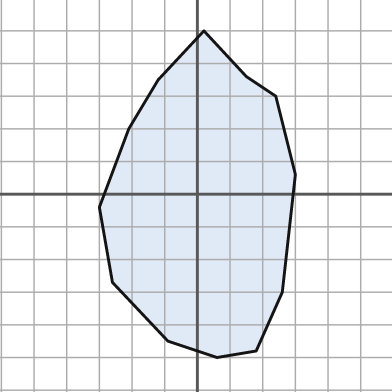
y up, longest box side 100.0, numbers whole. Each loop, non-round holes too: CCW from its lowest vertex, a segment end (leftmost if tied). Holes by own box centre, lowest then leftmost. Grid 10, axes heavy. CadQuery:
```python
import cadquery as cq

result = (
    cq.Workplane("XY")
    .moveTo(6.0, -50.0)
    .lineTo(18.0, -48.0)
    .lineTo(26.0, -30.0)
    .lineTo(30.0, 6.0)
    .lineTo(24.0, 30.0)
    .lineTo(15.0, 36.0)
    .lineTo(2.0, 50.0)
    .lineTo(-12.0, 35.0)
    .lineTo(-21.0, 20.0)
    .lineTo(-30.0, -4.0)
    .lineTo(-26.0, -27.0)
    .lineTo(-9.0, -45.0)
    .close()
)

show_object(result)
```